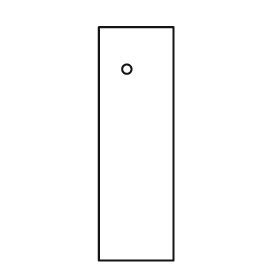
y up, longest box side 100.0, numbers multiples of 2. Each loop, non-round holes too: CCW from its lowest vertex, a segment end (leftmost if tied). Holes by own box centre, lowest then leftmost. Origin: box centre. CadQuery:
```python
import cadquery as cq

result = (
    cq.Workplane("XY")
    .moveTo(-16.0, -50.0)
    .lineTo(16.0, -50.0)
    .lineTo(16.0, 50.0)
    .lineTo(-16.0, 50.0)
    .close()
    .moveTo(-4.0, 32.0)
    .circle(2.0)
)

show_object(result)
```